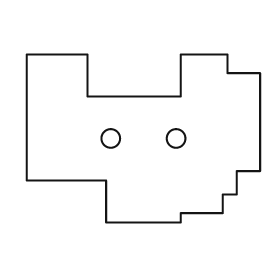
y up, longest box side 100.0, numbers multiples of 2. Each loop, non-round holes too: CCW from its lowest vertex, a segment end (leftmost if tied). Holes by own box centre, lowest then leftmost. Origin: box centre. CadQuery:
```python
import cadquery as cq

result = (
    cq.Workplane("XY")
    .moveTo(-16.0, -36.0)
    .lineTo(16.0, -36.0)
    .lineTo(16.0, -32.0)
    .lineTo(34.0, -32.0)
    .lineTo(34.0, -24.0)
    .lineTo(40.0, -24.0)
    .lineTo(40.0, -14.0)
    .lineTo(50.0, -14.0)
    .lineTo(50.0, 28.0)
    .lineTo(36.0, 28.0)
    .lineTo(36.0, 36.0)
    .lineTo(16.0, 36.0)
    .lineTo(16.0, 18.0)
    .lineTo(-24.0, 18.0)
    .lineTo(-24.0, 36.0)
    .lineTo(-50.0, 36.0)
    .lineTo(-50.0, -18.0)
    .lineTo(-16.0, -18.0)
    .close()
    .moveTo(-14.0, 0.0)
    .circle(4.0)
    .moveTo(14.0, 0.0)
    .circle(4.0)
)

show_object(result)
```